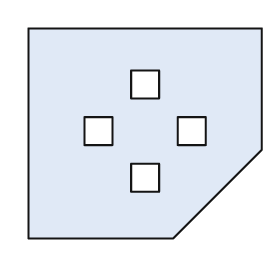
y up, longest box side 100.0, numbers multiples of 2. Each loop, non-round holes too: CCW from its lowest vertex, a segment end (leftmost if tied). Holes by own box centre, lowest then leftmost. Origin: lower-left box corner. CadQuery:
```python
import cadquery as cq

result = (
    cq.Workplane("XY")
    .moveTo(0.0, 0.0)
    .lineTo(62.0, 0.0)
    .lineTo(100.0, 38.0)
    .lineTo(100.0, 90.0)
    .lineTo(0.0, 90.0)
    .close()
    .moveTo(44.0, 20.0)
    .lineTo(56.0, 20.0)
    .lineTo(56.0, 32.0)
    .lineTo(44.0, 32.0)
    .close()
    .moveTo(24.0, 40.0)
    .lineTo(36.0, 40.0)
    .lineTo(36.0, 52.0)
    .lineTo(24.0, 52.0)
    .close()
    .moveTo(64.0, 40.0)
    .lineTo(76.0, 40.0)
    .lineTo(76.0, 52.0)
    .lineTo(64.0, 52.0)
    .close()
    .moveTo(44.0, 60.0)
    .lineTo(56.0, 60.0)
    .lineTo(56.0, 72.0)
    .lineTo(44.0, 72.0)
    .close()
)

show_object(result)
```